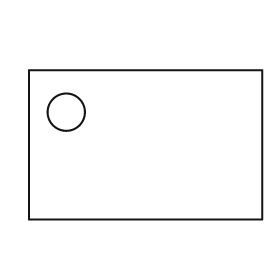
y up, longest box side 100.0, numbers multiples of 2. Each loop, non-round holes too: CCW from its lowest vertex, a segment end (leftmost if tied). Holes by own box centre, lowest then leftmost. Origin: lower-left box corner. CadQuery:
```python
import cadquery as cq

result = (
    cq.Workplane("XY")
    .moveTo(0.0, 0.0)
    .lineTo(100.0, 0.0)
    .lineTo(100.0, 64.0)
    .lineTo(0.0, 64.0)
    .close()
    .moveTo(16.0, 46.0)
    .circle(8.0)
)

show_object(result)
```